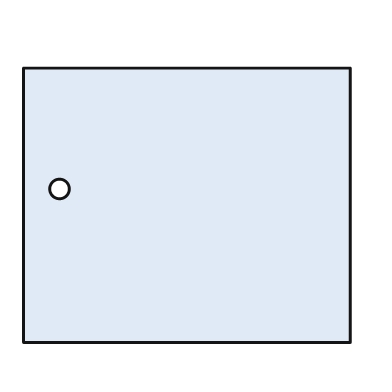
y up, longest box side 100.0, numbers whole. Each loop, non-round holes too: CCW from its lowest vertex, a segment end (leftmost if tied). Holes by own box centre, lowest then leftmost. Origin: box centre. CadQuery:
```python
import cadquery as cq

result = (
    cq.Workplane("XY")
    .moveTo(-50.0, -42.0)
    .lineTo(50.0, -42.0)
    .lineTo(50.0, 42.0)
    .lineTo(-50.0, 42.0)
    .close()
    .moveTo(-39.0, 5.0)
    .circle(3.0)
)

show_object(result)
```